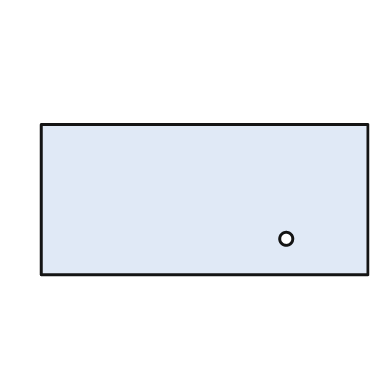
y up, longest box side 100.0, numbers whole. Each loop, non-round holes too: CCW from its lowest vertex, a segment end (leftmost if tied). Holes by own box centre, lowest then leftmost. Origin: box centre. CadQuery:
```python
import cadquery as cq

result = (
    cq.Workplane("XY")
    .moveTo(-50.0, -23.0)
    .lineTo(50.0, -23.0)
    .lineTo(50.0, 23.0)
    .lineTo(-50.0, 23.0)
    .close()
    .moveTo(25.0, -12.0)
    .circle(2.0)
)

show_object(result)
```